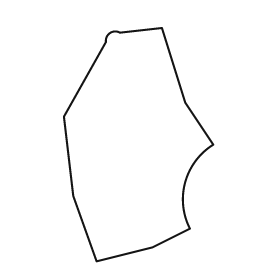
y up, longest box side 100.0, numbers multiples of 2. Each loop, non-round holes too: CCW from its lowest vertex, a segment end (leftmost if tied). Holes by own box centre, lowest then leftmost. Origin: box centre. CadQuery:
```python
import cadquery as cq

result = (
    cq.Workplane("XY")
    .moveTo(-18.0, -50.0)
    .lineTo(6.0, -44.0)
    .lineTo(22.0, -36.0)
    .threePointArc((20.0, -16.0), (32.0, 0.0))
    .lineTo(20.0, 18.0)
    .lineTo(10.0, 50.0)
    .lineTo(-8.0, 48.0)
    .threePointArc((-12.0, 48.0), (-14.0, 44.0))
    .lineTo(-32.0, 12.0)
    .lineTo(-28.0, -22.0)
    .close()
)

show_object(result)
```